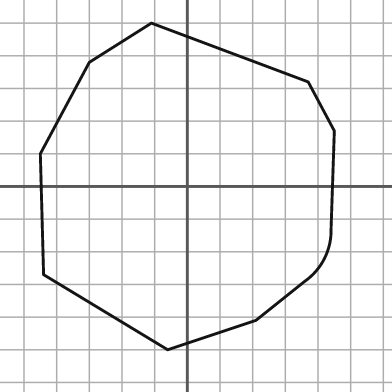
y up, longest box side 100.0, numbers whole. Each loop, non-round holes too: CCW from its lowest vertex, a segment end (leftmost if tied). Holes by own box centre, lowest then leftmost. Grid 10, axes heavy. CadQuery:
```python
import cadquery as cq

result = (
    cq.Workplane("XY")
    .moveTo(-6.0, -50.0)
    .lineTo(21.0, -41.0)
    .lineTo(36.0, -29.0)
    .threePointArc((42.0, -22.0), (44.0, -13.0))
    .lineTo(45.0, 17.0)
    .lineTo(37.0, 32.0)
    .lineTo(-11.0, 50.0)
    .lineTo(-30.0, 38.0)
    .lineTo(-45.0, 10.0)
    .lineTo(-44.0, -27.0)
    .close()
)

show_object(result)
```